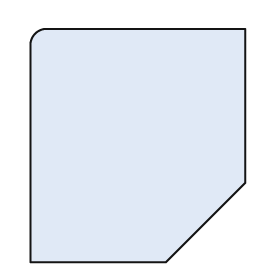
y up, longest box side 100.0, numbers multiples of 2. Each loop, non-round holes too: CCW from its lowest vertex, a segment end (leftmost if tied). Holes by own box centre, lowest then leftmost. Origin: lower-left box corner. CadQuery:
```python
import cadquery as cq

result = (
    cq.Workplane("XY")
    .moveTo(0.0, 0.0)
    .lineTo(58.0, 0.0)
    .lineTo(92.0, 34.0)
    .lineTo(92.0, 100.0)
    .lineTo(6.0, 100.0)
    .threePointArc((2.0, 98.0), (0.0, 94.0))
    .close()
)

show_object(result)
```